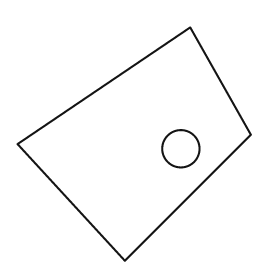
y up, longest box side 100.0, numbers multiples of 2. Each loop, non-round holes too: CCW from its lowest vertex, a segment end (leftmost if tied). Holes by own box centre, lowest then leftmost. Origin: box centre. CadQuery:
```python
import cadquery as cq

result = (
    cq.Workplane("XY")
    .moveTo(-4.0, -50.0)
    .lineTo(50.0, 4.0)
    .lineTo(24.0, 50.0)
    .lineTo(-50.0, 0.0)
    .close()
    .moveTo(20.0, -2.0)
    .circle(8.0)
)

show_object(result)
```